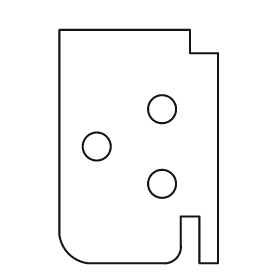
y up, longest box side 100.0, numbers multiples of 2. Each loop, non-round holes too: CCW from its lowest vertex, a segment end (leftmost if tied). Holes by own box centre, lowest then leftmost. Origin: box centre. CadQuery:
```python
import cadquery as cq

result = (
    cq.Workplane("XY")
    .moveTo(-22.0, -50.0)
    .lineTo(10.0, -50.0)
    .threePointArc((16.0, -48.0), (18.0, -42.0))
    .lineTo(18.0, -30.0)
    .lineTo(26.0, -30.0)
    .lineTo(26.0, -50.0)
    .lineTo(34.0, -50.0)
    .lineTo(34.0, 40.0)
    .lineTo(22.0, 40.0)
    .lineTo(22.0, 50.0)
    .lineTo(-34.0, 50.0)
    .lineTo(-34.0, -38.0)
    .threePointArc((-30.0, -46.0), (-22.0, -50.0))
    .close()
    .moveTo(10.0, -16.0)
    .circle(6.0)
    .moveTo(-18.0, 0.0)
    .circle(6.0)
    .moveTo(10.0, 16.0)
    .circle(6.0)
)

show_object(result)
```